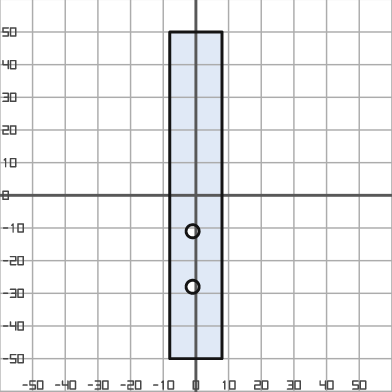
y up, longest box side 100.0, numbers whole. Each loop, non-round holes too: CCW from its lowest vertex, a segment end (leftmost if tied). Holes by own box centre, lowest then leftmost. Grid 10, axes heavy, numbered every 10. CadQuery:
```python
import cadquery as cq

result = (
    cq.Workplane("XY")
    .moveTo(-8.0, -50.0)
    .lineTo(8.0, -50.0)
    .lineTo(8.0, 50.0)
    .lineTo(-8.0, 50.0)
    .close()
    .moveTo(-1.0, -28.0)
    .circle(2.0)
    .moveTo(-1.0, -11.0)
    .circle(2.0)
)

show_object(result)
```